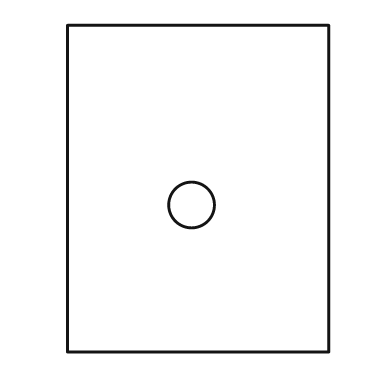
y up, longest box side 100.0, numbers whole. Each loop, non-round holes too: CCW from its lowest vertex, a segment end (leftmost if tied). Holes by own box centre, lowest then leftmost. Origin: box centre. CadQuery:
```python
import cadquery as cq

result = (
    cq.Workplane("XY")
    .moveTo(-40.0, -50.0)
    .lineTo(40.0, -50.0)
    .lineTo(40.0, 50.0)
    .lineTo(-40.0, 50.0)
    .close()
    .moveTo(-2.0, -5.0)
    .circle(7.0)
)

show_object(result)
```